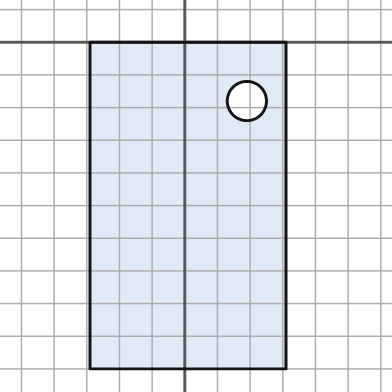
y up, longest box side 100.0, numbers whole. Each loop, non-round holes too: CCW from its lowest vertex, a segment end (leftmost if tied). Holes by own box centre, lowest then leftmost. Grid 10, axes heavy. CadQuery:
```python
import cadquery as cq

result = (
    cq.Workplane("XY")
    .moveTo(-29.0, -100.0)
    .lineTo(31.0, -100.0)
    .lineTo(31.0, 0.0)
    .lineTo(-29.0, 0.0)
    .close()
    .moveTo(19.0, -18.0)
    .circle(6.0)
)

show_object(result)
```